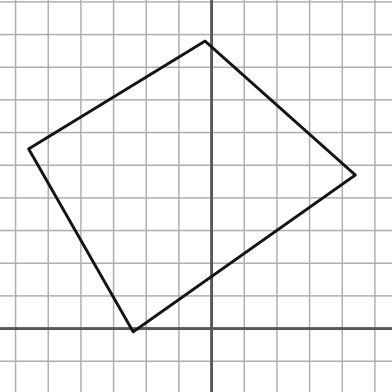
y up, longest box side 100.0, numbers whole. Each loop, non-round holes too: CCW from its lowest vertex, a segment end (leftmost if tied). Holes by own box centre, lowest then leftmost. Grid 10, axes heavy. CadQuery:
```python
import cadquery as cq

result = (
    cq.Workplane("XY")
    .moveTo(-24.0, -1.0)
    .lineTo(44.0, 47.0)
    .lineTo(-2.0, 88.0)
    .lineTo(-56.0, 55.0)
    .close()
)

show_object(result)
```